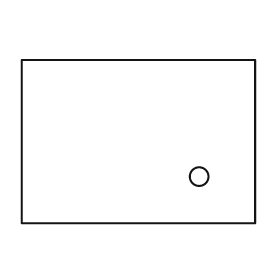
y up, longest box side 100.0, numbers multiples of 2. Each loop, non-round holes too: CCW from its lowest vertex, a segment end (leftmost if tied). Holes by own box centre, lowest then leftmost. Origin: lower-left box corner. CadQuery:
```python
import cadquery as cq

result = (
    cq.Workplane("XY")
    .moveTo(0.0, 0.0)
    .lineTo(100.0, 0.0)
    .lineTo(100.0, 70.0)
    .lineTo(0.0, 70.0)
    .close()
    .moveTo(76.0, 20.0)
    .circle(4.0)
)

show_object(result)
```